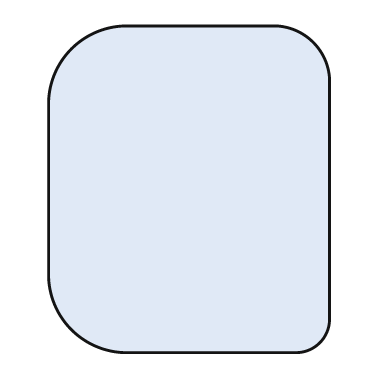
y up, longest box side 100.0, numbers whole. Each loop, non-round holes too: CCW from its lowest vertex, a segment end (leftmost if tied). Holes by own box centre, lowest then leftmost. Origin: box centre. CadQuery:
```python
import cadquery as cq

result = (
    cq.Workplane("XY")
    .moveTo(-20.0, -50.0)
    .lineTo(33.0, -50.0)
    .threePointArc((40.0, -47.0), (43.0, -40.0))
    .lineTo(43.0, 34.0)
    .threePointArc((38.0, 45.0), (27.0, 50.0))
    .lineTo(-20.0, 50.0)
    .threePointArc((-36.0, 43.0), (-43.0, 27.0))
    .lineTo(-43.0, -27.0)
    .threePointArc((-36.0, -43.0), (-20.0, -50.0))
    .close()
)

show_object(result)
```